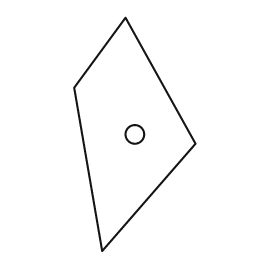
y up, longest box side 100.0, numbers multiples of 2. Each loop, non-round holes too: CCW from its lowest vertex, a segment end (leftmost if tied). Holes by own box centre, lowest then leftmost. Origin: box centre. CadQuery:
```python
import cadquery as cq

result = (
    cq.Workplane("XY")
    .moveTo(-14.0, -50.0)
    .lineTo(26.0, -4.0)
    .lineTo(-4.0, 50.0)
    .lineTo(-26.0, 20.0)
    .close()
    .moveTo(0.0, 0.0)
    .circle(4.0)
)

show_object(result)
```